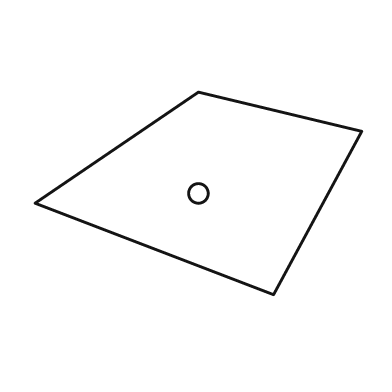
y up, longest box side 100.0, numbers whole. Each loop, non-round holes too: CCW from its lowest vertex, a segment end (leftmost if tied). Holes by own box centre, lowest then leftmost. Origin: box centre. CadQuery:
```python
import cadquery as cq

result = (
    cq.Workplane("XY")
    .moveTo(23.0, -31.0)
    .lineTo(50.0, 19.0)
    .lineTo(0.0, 31.0)
    .lineTo(-50.0, -3.0)
    .close()
    .moveTo(0.0, 0.0)
    .circle(3.0)
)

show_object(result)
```